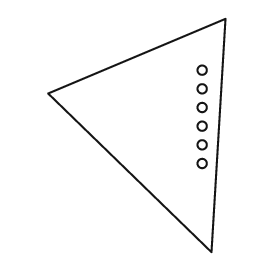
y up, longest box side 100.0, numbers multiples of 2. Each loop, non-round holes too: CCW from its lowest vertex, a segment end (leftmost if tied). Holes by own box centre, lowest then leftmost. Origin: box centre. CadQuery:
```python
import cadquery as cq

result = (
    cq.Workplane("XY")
    .moveTo(32.0, -50.0)
    .lineTo(38.0, 50.0)
    .lineTo(-38.0, 18.0)
    .close()
    .moveTo(28.0, -12.0)
    .circle(2.0)
    .moveTo(28.0, -4.0)
    .circle(2.0)
    .moveTo(28.0, 4.0)
    .circle(2.0)
    .moveTo(28.0, 12.0)
    .circle(2.0)
    .moveTo(28.0, 20.0)
    .circle(2.0)
    .moveTo(28.0, 28.0)
    .circle(2.0)
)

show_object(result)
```